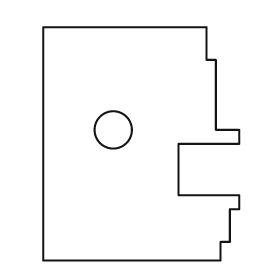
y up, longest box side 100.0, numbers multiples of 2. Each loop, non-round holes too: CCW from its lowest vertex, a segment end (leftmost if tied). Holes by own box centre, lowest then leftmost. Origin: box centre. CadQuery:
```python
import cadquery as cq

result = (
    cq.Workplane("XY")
    .moveTo(-42.0, -50.0)
    .lineTo(34.0, -50.0)
    .lineTo(34.0, -42.0)
    .lineTo(38.0, -42.0)
    .lineTo(38.0, -28.0)
    .lineTo(42.0, -28.0)
    .lineTo(42.0, -22.0)
    .lineTo(16.0, -22.0)
    .lineTo(16.0, 0.0)
    .lineTo(42.0, 0.0)
    .lineTo(42.0, 6.0)
    .lineTo(32.0, 6.0)
    .lineTo(32.0, 36.0)
    .lineTo(28.0, 36.0)
    .lineTo(28.0, 50.0)
    .lineTo(-42.0, 50.0)
    .close()
    .moveTo(-12.0, 6.0)
    .circle(8.0)
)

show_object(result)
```